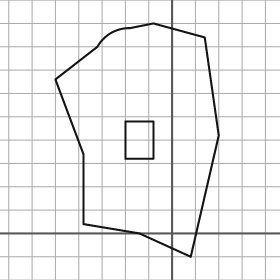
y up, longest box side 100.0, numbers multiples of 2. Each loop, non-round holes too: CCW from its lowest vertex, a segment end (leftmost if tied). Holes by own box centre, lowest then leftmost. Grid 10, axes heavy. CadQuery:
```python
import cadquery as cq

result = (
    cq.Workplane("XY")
    .moveTo(8.0, -10.0)
    .lineTo(20.0, 42.0)
    .lineTo(14.0, 84.0)
    .lineTo(-8.0, 90.0)
    .lineTo(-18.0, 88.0)
    .threePointArc((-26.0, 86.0), (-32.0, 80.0))
    .lineTo(-50.0, 66.0)
    .lineTo(-38.0, 34.0)
    .lineTo(-38.0, 4.0)
    .lineTo(-14.0, 0.0)
    .close()
    .moveTo(-20.0, 32.0)
    .lineTo(-8.0, 32.0)
    .lineTo(-8.0, 48.0)
    .lineTo(-20.0, 48.0)
    .close()
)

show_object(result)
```